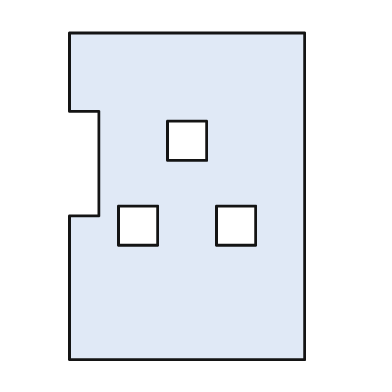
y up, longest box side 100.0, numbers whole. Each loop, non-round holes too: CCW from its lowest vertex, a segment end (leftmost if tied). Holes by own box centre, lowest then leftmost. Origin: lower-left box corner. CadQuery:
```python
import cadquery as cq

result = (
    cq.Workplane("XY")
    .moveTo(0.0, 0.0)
    .lineTo(72.0, 0.0)
    .lineTo(72.0, 100.0)
    .lineTo(0.0, 100.0)
    .lineTo(0.0, 76.0)
    .lineTo(9.0, 76.0)
    .lineTo(9.0, 44.0)
    .lineTo(0.0, 44.0)
    .close()
    .moveTo(15.0, 35.0)
    .lineTo(27.0, 35.0)
    .lineTo(27.0, 47.0)
    .lineTo(15.0, 47.0)
    .close()
    .moveTo(45.0, 35.0)
    .lineTo(57.0, 35.0)
    .lineTo(57.0, 47.0)
    .lineTo(45.0, 47.0)
    .close()
    .moveTo(30.0, 61.0)
    .lineTo(42.0, 61.0)
    .lineTo(42.0, 73.0)
    .lineTo(30.0, 73.0)
    .close()
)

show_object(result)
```